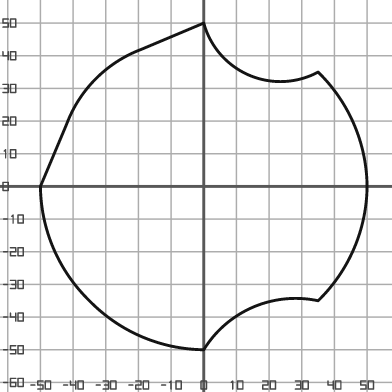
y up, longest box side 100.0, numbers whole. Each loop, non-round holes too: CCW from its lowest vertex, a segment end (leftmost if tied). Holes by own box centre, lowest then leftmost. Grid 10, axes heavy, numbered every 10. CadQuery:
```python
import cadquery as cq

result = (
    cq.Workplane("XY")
    .moveTo(0.0, -50.0)
    .threePointArc((15.0, -37.0), (35.0, -35.0))
    .threePointArc((46.0, -19.0), (50.0, 0.0))
    .threePointArc((46.0, 19.0), (35.0, 35.0))
    .threePointArc((14.0, 34.0), (0.0, 50.0))
    .lineTo(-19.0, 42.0)
    .threePointArc((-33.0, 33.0), (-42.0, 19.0))
    .lineTo(-50.0, 0.0)
    .threePointArc((-46.0, -19.0), (-35.0, -35.0))
    .threePointArc((-19.0, -46.0), (0.0, -50.0))
    .close()
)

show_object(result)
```